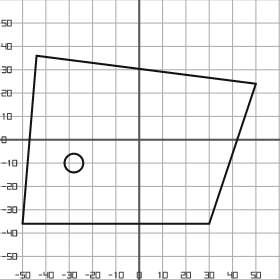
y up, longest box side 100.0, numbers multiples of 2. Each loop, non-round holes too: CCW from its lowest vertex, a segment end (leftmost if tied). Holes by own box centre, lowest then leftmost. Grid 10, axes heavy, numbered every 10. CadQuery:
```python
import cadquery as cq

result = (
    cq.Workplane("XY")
    .moveTo(-50.0, -36.0)
    .lineTo(30.0, -36.0)
    .lineTo(50.0, 24.0)
    .lineTo(-44.0, 36.0)
    .close()
    .moveTo(-28.0, -10.0)
    .circle(4.0)
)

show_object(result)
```